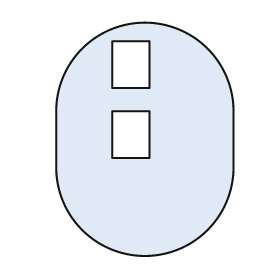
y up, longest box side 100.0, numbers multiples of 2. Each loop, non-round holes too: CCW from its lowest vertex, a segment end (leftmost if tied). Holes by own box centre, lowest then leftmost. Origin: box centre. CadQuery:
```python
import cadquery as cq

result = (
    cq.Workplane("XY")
    .moveTo(-38.0, -12.0)
    .threePointArc((0.0, -50.0), (38.0, -12.0))
    .lineTo(38.0, 12.0)
    .threePointArc((0.0, 50.0), (-38.0, 12.0))
    .close()
    .moveTo(-14.0, -8.0)
    .lineTo(2.0, -8.0)
    .lineTo(2.0, 12.0)
    .lineTo(-14.0, 12.0)
    .close()
    .moveTo(-14.0, 22.0)
    .lineTo(2.0, 22.0)
    .lineTo(2.0, 42.0)
    .lineTo(-14.0, 42.0)
    .close()
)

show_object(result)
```